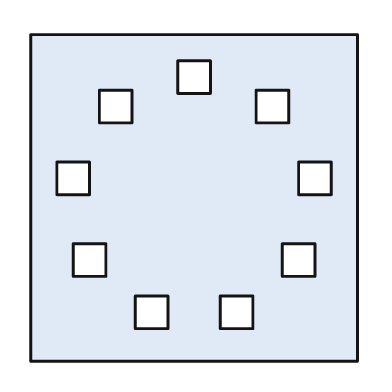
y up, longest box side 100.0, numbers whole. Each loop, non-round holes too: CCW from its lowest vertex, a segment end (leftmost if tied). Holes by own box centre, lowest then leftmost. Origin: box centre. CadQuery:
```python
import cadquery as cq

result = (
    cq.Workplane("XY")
    .moveTo(-50.0, -50.0)
    .lineTo(50.0, -50.0)
    .lineTo(50.0, 50.0)
    .lineTo(-50.0, 50.0)
    .close()
    .moveTo(-18.0, -40.0)
    .lineTo(-8.0, -40.0)
    .lineTo(-8.0, -30.0)
    .lineTo(-18.0, -30.0)
    .close()
    .moveTo(8.0, -40.0)
    .lineTo(18.0, -40.0)
    .lineTo(18.0, -30.0)
    .lineTo(8.0, -30.0)
    .close()
    .moveTo(-37.0, -24.0)
    .lineTo(-27.0, -24.0)
    .lineTo(-27.0, -14.0)
    .lineTo(-37.0, -14.0)
    .close()
    .moveTo(27.0, -24.0)
    .lineTo(37.0, -24.0)
    .lineTo(37.0, -14.0)
    .lineTo(27.0, -14.0)
    .close()
    .moveTo(-42.0, 1.0)
    .lineTo(-32.0, 1.0)
    .lineTo(-32.0, 11.0)
    .lineTo(-42.0, 11.0)
    .close()
    .moveTo(32.0, 1.0)
    .lineTo(42.0, 1.0)
    .lineTo(42.0, 11.0)
    .lineTo(32.0, 11.0)
    .close()
    .moveTo(-29.0, 23.0)
    .lineTo(-19.0, 23.0)
    .lineTo(-19.0, 33.0)
    .lineTo(-29.0, 33.0)
    .close()
    .moveTo(19.0, 23.0)
    .lineTo(29.0, 23.0)
    .lineTo(29.0, 33.0)
    .lineTo(19.0, 33.0)
    .close()
    .moveTo(-5.0, 32.0)
    .lineTo(5.0, 32.0)
    .lineTo(5.0, 42.0)
    .lineTo(-5.0, 42.0)
    .close()
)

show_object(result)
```